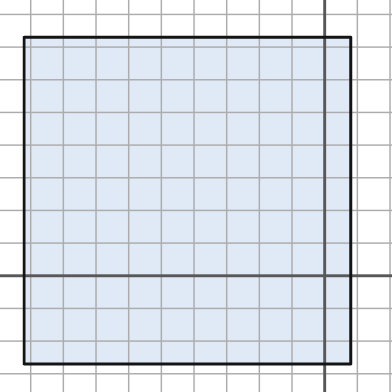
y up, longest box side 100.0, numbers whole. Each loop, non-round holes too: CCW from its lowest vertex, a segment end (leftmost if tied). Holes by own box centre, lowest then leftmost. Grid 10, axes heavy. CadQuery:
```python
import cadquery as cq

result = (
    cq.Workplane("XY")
    .moveTo(-92.0, -27.0)
    .lineTo(8.0, -27.0)
    .lineTo(8.0, 73.0)
    .lineTo(-92.0, 73.0)
    .close()
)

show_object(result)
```